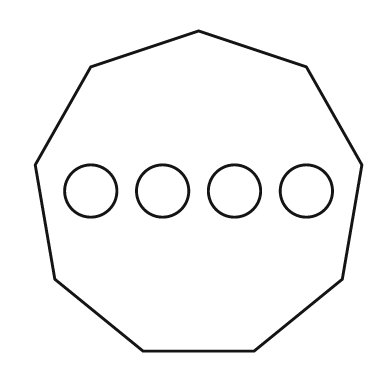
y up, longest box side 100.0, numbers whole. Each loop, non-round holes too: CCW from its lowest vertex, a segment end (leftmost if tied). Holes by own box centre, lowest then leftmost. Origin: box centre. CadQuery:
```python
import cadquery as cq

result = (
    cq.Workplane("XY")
    .moveTo(-17.0, -49.0)
    .lineTo(17.0, -49.0)
    .lineTo(44.0, -27.0)
    .lineTo(50.0, 8.0)
    .lineTo(33.0, 38.0)
    .lineTo(0.0, 49.0)
    .lineTo(-33.0, 38.0)
    .lineTo(-50.0, 8.0)
    .lineTo(-44.0, -27.0)
    .close()
    .moveTo(-33.0, 0.0)
    .circle(8.0)
    .moveTo(-11.0, 0.0)
    .circle(8.0)
    .moveTo(11.0, 0.0)
    .circle(8.0)
    .moveTo(33.0, 0.0)
    .circle(8.0)
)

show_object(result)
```